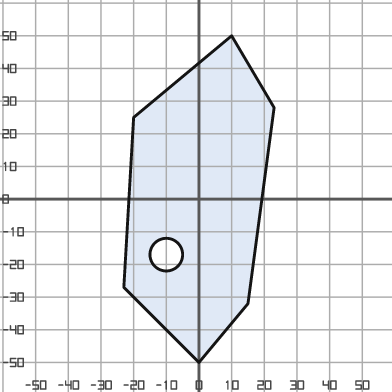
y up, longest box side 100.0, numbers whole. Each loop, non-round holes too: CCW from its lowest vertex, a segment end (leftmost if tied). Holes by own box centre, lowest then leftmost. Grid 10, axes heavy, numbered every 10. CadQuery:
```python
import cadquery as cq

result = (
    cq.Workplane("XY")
    .moveTo(0.0, -50.0)
    .lineTo(15.0, -32.0)
    .lineTo(23.0, 28.0)
    .lineTo(10.0, 50.0)
    .lineTo(-20.0, 25.0)
    .lineTo(-23.0, -27.0)
    .close()
    .moveTo(-10.0, -17.0)
    .circle(5.0)
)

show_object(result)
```